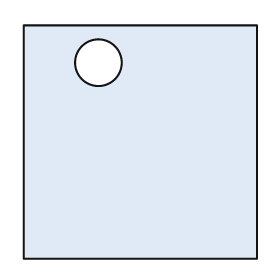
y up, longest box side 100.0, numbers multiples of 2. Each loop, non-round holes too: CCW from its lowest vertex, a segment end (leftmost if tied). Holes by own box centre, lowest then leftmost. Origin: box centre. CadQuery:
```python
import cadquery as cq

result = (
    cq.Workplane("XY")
    .moveTo(-50.0, -50.0)
    .lineTo(50.0, -50.0)
    .lineTo(50.0, 50.0)
    .lineTo(-50.0, 50.0)
    .close()
    .moveTo(-18.0, 34.0)
    .circle(10.0)
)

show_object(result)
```